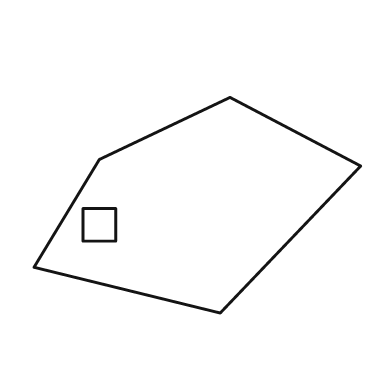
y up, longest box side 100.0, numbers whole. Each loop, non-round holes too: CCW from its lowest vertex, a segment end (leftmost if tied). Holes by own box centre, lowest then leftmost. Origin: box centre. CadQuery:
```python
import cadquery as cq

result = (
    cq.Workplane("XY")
    .moveTo(7.0, -33.0)
    .lineTo(50.0, 12.0)
    .lineTo(10.0, 33.0)
    .lineTo(-30.0, 14.0)
    .lineTo(-50.0, -19.0)
    .close()
    .moveTo(-35.0, -11.0)
    .lineTo(-25.0, -11.0)
    .lineTo(-25.0, -1.0)
    .lineTo(-35.0, -1.0)
    .close()
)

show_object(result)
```